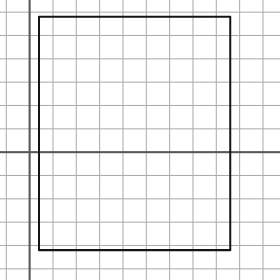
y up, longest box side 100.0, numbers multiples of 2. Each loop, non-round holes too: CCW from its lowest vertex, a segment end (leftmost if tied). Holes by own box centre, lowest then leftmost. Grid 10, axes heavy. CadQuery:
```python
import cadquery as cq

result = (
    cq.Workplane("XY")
    .moveTo(4.0, -42.0)
    .lineTo(86.0, -42.0)
    .lineTo(86.0, 58.0)
    .lineTo(4.0, 58.0)
    .close()
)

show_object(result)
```